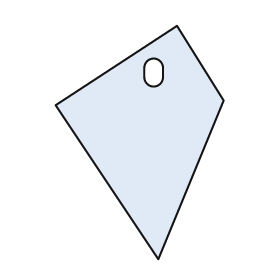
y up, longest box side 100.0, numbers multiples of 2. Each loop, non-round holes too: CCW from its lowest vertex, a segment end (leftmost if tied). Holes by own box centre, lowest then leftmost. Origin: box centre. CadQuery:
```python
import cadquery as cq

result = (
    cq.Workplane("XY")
    .moveTo(8.0, -50.0)
    .lineTo(36.0, 18.0)
    .lineTo(16.0, 50.0)
    .lineTo(-36.0, 16.0)
    .close()
    .moveTo(2.0, 28.0)
    .threePointArc((6.0, 24.0), (10.0, 28.0))
    .lineTo(10.0, 32.0)
    .threePointArc((6.0, 36.0), (2.0, 32.0))
    .close()
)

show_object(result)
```